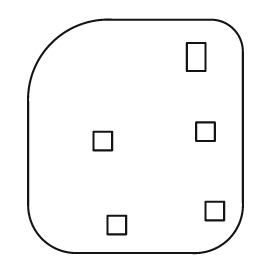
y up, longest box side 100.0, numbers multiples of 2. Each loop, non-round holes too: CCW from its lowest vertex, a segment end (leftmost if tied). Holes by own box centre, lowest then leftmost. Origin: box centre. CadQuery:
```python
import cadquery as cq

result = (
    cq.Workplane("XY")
    .moveTo(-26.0, -50.0)
    .lineTo(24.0, -50.0)
    .threePointArc((40.0, -44.0), (46.0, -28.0))
    .lineTo(46.0, 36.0)
    .threePointArc((42.0, 46.0), (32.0, 50.0))
    .lineTo(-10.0, 50.0)
    .threePointArc((-36.0, 40.0), (-46.0, 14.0))
    .lineTo(-46.0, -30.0)
    .threePointArc((-40.0, -44.0), (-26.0, -50.0))
    .close()
    .moveTo(-12.0, -42.0)
    .lineTo(-4.0, -42.0)
    .lineTo(-4.0, -34.0)
    .lineTo(-12.0, -34.0)
    .close()
    .moveTo(30.0, -36.0)
    .lineTo(38.0, -36.0)
    .lineTo(38.0, -28.0)
    .lineTo(30.0, -28.0)
    .close()
    .moveTo(-18.0, -6.0)
    .lineTo(-10.0, -6.0)
    .lineTo(-10.0, 2.0)
    .lineTo(-18.0, 2.0)
    .close()
    .moveTo(26.0, -2.0)
    .lineTo(34.0, -2.0)
    .lineTo(34.0, 6.0)
    .lineTo(26.0, 6.0)
    .close()
    .moveTo(22.0, 28.0)
    .lineTo(30.0, 28.0)
    .lineTo(30.0, 40.0)
    .lineTo(22.0, 40.0)
    .close()
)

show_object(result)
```